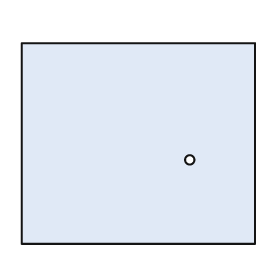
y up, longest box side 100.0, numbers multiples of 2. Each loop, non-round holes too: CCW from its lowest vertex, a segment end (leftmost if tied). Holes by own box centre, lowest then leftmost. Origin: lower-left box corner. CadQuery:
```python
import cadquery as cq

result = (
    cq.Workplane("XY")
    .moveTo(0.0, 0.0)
    .lineTo(100.0, 0.0)
    .lineTo(100.0, 86.0)
    .lineTo(0.0, 86.0)
    .close()
    .moveTo(72.0, 36.0)
    .circle(2.0)
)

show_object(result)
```